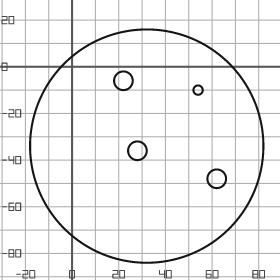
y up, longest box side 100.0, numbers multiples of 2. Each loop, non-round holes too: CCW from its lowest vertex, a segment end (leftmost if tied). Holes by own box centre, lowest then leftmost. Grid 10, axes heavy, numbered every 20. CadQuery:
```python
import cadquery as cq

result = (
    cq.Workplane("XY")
    .moveTo(32.0, -34.0)
    .circle(50.0)
    .moveTo(62.0, -48.0)
    .circle(4.0)
    .moveTo(28.0, -36.0)
    .circle(4.0)
    .moveTo(54.0, -10.0)
    .circle(2.0)
    .moveTo(22.0, -6.0)
    .circle(4.0)
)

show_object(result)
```